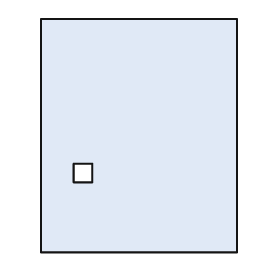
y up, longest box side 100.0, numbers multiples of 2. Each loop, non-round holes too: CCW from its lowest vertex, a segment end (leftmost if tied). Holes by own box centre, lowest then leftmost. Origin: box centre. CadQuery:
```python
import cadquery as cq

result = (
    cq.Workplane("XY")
    .moveTo(-42.0, -50.0)
    .lineTo(42.0, -50.0)
    .lineTo(42.0, 50.0)
    .lineTo(-42.0, 50.0)
    .close()
    .moveTo(-28.0, -20.0)
    .lineTo(-20.0, -20.0)
    .lineTo(-20.0, -12.0)
    .lineTo(-28.0, -12.0)
    .close()
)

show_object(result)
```